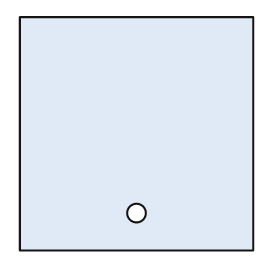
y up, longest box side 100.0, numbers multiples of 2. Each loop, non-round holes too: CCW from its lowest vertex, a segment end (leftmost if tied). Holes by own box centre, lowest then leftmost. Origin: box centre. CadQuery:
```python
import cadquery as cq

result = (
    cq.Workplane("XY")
    .moveTo(-50.0, -50.0)
    .lineTo(50.0, -50.0)
    .lineTo(50.0, 50.0)
    .lineTo(-50.0, 50.0)
    .close()
    .moveTo(0.0, -34.0)
    .circle(4.0)
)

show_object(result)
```